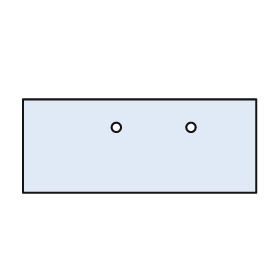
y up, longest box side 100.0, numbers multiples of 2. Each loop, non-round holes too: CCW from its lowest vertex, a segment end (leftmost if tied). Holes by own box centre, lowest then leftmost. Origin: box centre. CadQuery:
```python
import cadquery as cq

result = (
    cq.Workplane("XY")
    .moveTo(-50.0, -20.0)
    .lineTo(50.0, -20.0)
    .lineTo(50.0, 20.0)
    .lineTo(-50.0, 20.0)
    .close()
    .moveTo(-10.0, 8.0)
    .circle(2.0)
    .moveTo(22.0, 8.0)
    .circle(2.0)
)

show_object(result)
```